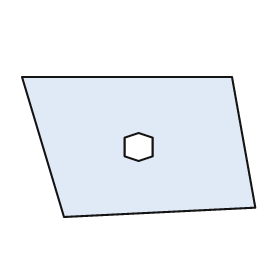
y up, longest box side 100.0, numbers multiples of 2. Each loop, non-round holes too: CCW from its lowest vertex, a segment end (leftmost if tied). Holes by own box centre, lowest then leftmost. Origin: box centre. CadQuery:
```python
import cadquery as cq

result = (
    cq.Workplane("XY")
    .moveTo(-32.0, -30.0)
    .lineTo(50.0, -26.0)
    .lineTo(40.0, 30.0)
    .lineTo(-50.0, 30.0)
    .close()
    .moveTo(0.0, -6.0)
    .lineTo(6.0, -4.0)
    .lineTo(6.0, 4.0)
    .lineTo(0.0, 6.0)
    .lineTo(-6.0, 4.0)
    .lineTo(-6.0, -4.0)
    .close()
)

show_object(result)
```